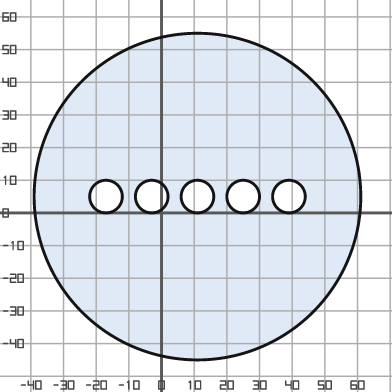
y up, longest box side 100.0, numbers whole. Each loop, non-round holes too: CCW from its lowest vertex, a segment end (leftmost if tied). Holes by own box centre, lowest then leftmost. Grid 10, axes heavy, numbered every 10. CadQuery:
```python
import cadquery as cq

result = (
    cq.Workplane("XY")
    .moveTo(11.0, 5.0)
    .circle(50.0)
    .moveTo(-17.0, 5.0)
    .circle(5.0)
    .moveTo(-3.0, 5.0)
    .circle(5.0)
    .moveTo(11.0, 5.0)
    .circle(5.0)
    .moveTo(25.0, 5.0)
    .circle(5.0)
    .moveTo(39.0, 5.0)
    .circle(5.0)
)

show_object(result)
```